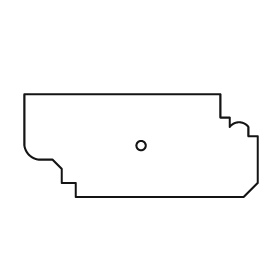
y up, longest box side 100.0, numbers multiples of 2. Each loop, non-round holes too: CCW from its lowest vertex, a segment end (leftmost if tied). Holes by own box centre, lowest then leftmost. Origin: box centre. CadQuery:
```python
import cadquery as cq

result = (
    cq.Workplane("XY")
    .moveTo(-28.0, -22.0)
    .lineTo(44.0, -22.0)
    .lineTo(50.0, -16.0)
    .lineTo(50.0, 4.0)
    .lineTo(46.0, 4.0)
    .lineTo(46.0, 8.0)
    .threePointArc((42.0, 10.0), (38.0, 8.0))
    .lineTo(38.0, 12.0)
    .lineTo(34.0, 12.0)
    .lineTo(34.0, 22.0)
    .lineTo(-50.0, 22.0)
    .lineTo(-50.0, 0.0)
    .threePointArc((-48.0, -4.0), (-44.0, -6.0))
    .lineTo(-38.0, -6.0)
    .lineTo(-34.0, -10.0)
    .lineTo(-34.0, -16.0)
    .lineTo(-28.0, -16.0)
    .close()
    .moveTo(0.0, 0.0)
    .circle(2.0)
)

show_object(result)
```